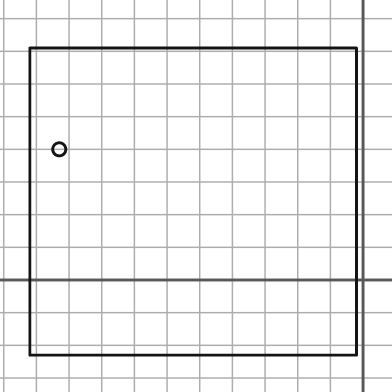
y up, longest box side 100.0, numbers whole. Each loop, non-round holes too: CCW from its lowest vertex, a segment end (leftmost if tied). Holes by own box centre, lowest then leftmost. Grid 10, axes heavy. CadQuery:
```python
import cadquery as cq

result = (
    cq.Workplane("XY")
    .moveTo(-102.0, -23.0)
    .lineTo(-2.0, -23.0)
    .lineTo(-2.0, 71.0)
    .lineTo(-102.0, 71.0)
    .close()
    .moveTo(-93.0, 40.0)
    .circle(2.0)
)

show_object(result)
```